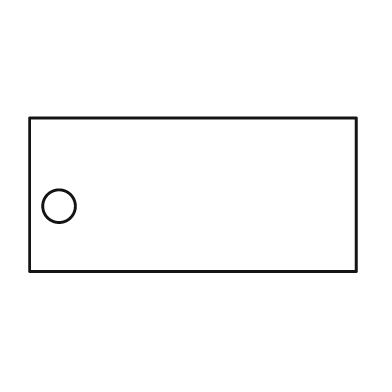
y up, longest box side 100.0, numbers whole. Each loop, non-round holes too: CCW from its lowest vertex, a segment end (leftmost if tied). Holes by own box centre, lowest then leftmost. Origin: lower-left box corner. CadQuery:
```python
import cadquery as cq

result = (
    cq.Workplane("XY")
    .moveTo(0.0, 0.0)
    .lineTo(100.0, 0.0)
    .lineTo(100.0, 47.0)
    .lineTo(0.0, 47.0)
    .close()
    .moveTo(9.0, 20.0)
    .circle(5.0)
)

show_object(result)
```